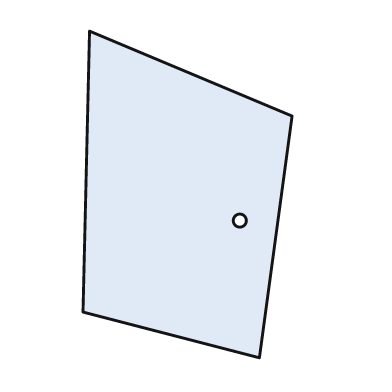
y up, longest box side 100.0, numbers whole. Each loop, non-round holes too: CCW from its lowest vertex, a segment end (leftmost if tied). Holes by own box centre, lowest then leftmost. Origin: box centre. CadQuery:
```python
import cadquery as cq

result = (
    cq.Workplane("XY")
    .moveTo(22.0, -50.0)
    .lineTo(32.0, 24.0)
    .lineTo(-30.0, 50.0)
    .lineTo(-32.0, -36.0)
    .close()
    .moveTo(16.0, -8.0)
    .circle(2.0)
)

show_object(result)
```